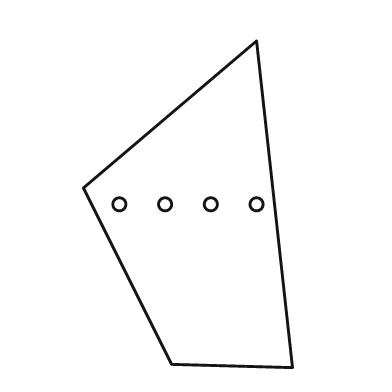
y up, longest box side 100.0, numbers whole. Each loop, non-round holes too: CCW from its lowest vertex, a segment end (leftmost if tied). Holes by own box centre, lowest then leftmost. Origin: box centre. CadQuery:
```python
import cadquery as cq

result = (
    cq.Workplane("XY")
    .moveTo(32.0, -50.0)
    .lineTo(21.0, 50.0)
    .lineTo(-32.0, 5.0)
    .lineTo(-5.0, -49.0)
    .close()
    .moveTo(-21.0, 0.0)
    .circle(2.0)
    .moveTo(-7.0, 0.0)
    .circle(2.0)
    .moveTo(7.0, 0.0)
    .circle(2.0)
    .moveTo(21.0, 0.0)
    .circle(2.0)
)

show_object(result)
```